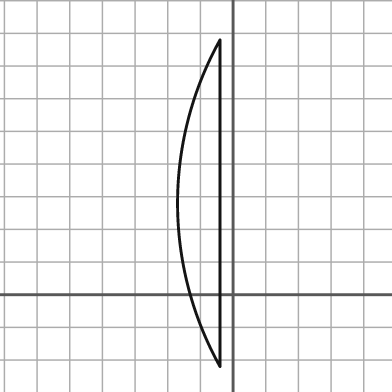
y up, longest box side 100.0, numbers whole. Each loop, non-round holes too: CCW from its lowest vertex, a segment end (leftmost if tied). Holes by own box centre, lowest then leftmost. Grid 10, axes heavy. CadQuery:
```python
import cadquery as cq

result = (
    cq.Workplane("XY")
    .moveTo(-4.0, -22.0)
    .lineTo(-4.0, 78.0)
    .threePointArc((-17.0, 28.0), (-4.0, -22.0))
    .close()
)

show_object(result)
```